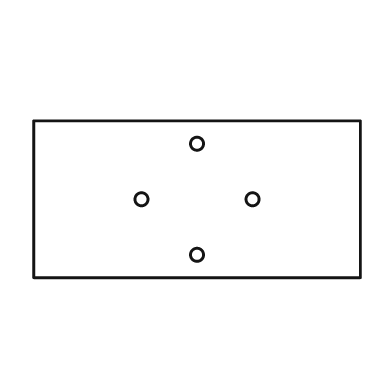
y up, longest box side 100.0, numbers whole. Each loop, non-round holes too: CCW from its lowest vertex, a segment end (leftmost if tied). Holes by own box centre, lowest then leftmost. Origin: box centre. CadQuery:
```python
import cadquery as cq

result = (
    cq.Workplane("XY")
    .moveTo(-50.0, -24.0)
    .lineTo(50.0, -24.0)
    .lineTo(50.0, 24.0)
    .lineTo(-50.0, 24.0)
    .close()
    .moveTo(0.0, -17.0)
    .circle(2.0)
    .moveTo(-17.0, 0.0)
    .circle(2.0)
    .moveTo(17.0, 0.0)
    .circle(2.0)
    .moveTo(0.0, 17.0)
    .circle(2.0)
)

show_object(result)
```